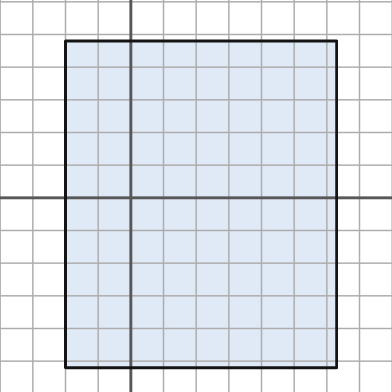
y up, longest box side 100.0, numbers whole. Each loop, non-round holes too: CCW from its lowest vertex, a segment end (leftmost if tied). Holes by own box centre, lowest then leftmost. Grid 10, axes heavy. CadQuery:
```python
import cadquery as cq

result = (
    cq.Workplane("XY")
    .moveTo(-20.0, -52.0)
    .lineTo(63.0, -52.0)
    .lineTo(63.0, 48.0)
    .lineTo(-20.0, 48.0)
    .close()
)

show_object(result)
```